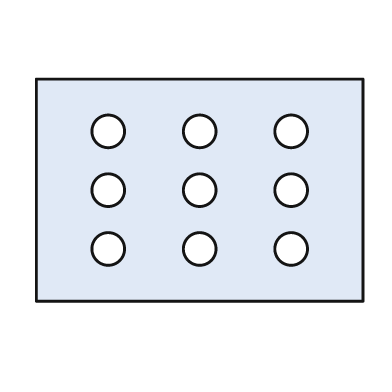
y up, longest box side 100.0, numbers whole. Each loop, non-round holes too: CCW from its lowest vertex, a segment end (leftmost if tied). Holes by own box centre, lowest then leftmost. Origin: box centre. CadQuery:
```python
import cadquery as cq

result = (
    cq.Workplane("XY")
    .moveTo(-50.0, -34.0)
    .lineTo(50.0, -34.0)
    .lineTo(50.0, 34.0)
    .lineTo(-50.0, 34.0)
    .close()
    .moveTo(-28.0, -18.0)
    .circle(5.0)
    .moveTo(0.0, -18.0)
    .circle(5.0)
    .moveTo(28.0, -18.0)
    .circle(5.0)
    .moveTo(-28.0, 0.0)
    .circle(5.0)
    .moveTo(0.0, 0.0)
    .circle(5.0)
    .moveTo(28.0, 0.0)
    .circle(5.0)
    .moveTo(-28.0, 18.0)
    .circle(5.0)
    .moveTo(0.0, 18.0)
    .circle(5.0)
    .moveTo(28.0, 18.0)
    .circle(5.0)
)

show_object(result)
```